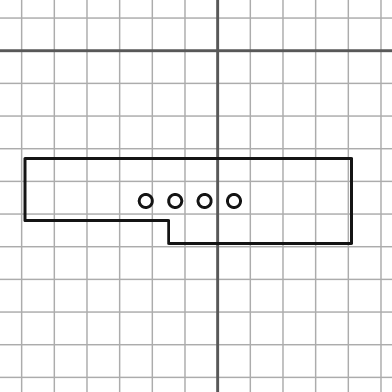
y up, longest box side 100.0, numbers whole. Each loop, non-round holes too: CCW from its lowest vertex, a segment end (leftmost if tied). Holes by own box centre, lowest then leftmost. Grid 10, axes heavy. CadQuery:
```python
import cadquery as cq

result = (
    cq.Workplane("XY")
    .moveTo(-15.0, -59.0)
    .lineTo(41.0, -59.0)
    .lineTo(41.0, -33.0)
    .lineTo(-59.0, -33.0)
    .lineTo(-59.0, -52.0)
    .lineTo(-15.0, -52.0)
    .close()
    .moveTo(-22.0, -46.0)
    .circle(2.0)
    .moveTo(-13.0, -46.0)
    .circle(2.0)
    .moveTo(-4.0, -46.0)
    .circle(2.0)
    .moveTo(5.0, -46.0)
    .circle(2.0)
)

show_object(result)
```